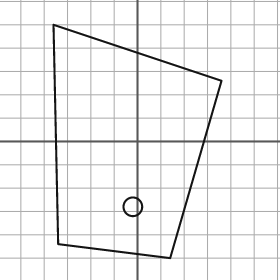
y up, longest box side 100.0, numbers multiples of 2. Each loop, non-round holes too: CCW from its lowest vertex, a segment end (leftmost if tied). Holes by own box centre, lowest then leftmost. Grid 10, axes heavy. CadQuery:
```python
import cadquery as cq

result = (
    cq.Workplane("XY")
    .moveTo(14.0, -50.0)
    .lineTo(36.0, 26.0)
    .lineTo(-36.0, 50.0)
    .lineTo(-34.0, -44.0)
    .close()
    .moveTo(-2.0, -28.0)
    .circle(4.0)
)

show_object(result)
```